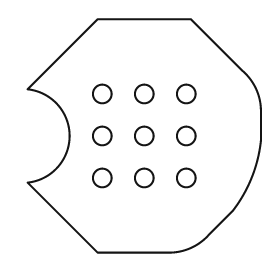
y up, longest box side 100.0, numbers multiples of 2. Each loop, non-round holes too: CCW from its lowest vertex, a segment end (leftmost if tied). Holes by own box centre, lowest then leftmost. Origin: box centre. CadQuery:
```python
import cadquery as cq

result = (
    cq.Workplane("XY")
    .moveTo(-20.0, -50.0)
    .lineTo(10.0, -50.0)
    .threePointArc((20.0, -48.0), (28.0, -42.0))
    .lineTo(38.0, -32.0)
    .threePointArc((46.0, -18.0), (50.0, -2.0))
    .lineTo(50.0, 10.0)
    .threePointArc((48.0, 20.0), (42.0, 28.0))
    .lineTo(20.0, 50.0)
    .lineTo(-20.0, 50.0)
    .lineTo(-50.0, 20.0)
    .threePointArc((-32.0, 0.0), (-50.0, -20.0))
    .close()
    .moveTo(-18.0, -18.0)
    .circle(4.0)
    .moveTo(0.0, -18.0)
    .circle(4.0)
    .moveTo(18.0, -18.0)
    .circle(4.0)
    .moveTo(-18.0, 0.0)
    .circle(4.0)
    .moveTo(0.0, 0.0)
    .circle(4.0)
    .moveTo(18.0, 0.0)
    .circle(4.0)
    .moveTo(-18.0, 18.0)
    .circle(4.0)
    .moveTo(0.0, 18.0)
    .circle(4.0)
    .moveTo(18.0, 18.0)
    .circle(4.0)
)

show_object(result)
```